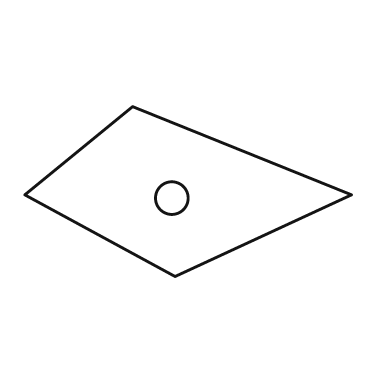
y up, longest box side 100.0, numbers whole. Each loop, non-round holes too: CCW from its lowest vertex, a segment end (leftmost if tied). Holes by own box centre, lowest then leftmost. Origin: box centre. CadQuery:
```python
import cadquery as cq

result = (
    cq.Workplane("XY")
    .moveTo(-4.0, -26.0)
    .lineTo(50.0, -1.0)
    .lineTo(-17.0, 26.0)
    .lineTo(-50.0, -1.0)
    .close()
    .moveTo(-5.0, -2.0)
    .circle(5.0)
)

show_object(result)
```